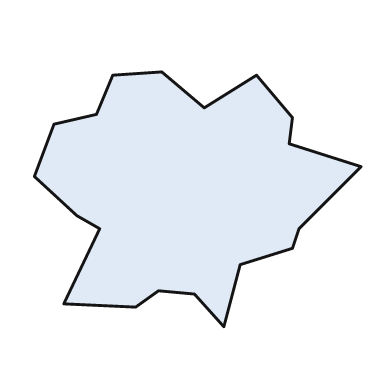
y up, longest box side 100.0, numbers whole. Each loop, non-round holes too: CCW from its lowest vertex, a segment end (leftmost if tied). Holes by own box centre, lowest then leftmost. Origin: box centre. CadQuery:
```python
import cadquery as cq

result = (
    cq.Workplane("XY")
    .moveTo(8.0, -39.0)
    .lineTo(13.0, -20.0)
    .lineTo(29.0, -15.0)
    .lineTo(31.0, -9.0)
    .lineTo(50.0, 10.0)
    .lineTo(28.0, 17.0)
    .lineTo(29.0, 25.0)
    .lineTo(18.0, 38.0)
    .lineTo(2.0, 28.0)
    .lineTo(-11.0, 39.0)
    .lineTo(-26.0, 38.0)
    .lineTo(-31.0, 26.0)
    .lineTo(-44.0, 23.0)
    .lineTo(-50.0, 7.0)
    .lineTo(-37.0, -5.0)
    .lineTo(-30.0, -9.0)
    .lineTo(-41.0, -32.0)
    .lineTo(-19.0, -33.0)
    .lineTo(-12.0, -28.0)
    .lineTo(-1.0, -29.0)
    .close()
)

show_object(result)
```